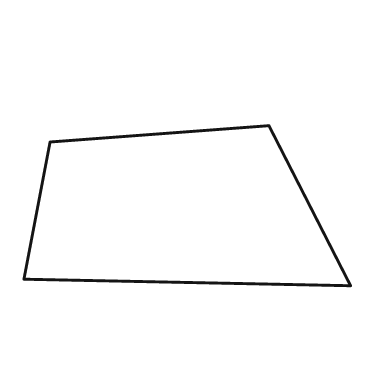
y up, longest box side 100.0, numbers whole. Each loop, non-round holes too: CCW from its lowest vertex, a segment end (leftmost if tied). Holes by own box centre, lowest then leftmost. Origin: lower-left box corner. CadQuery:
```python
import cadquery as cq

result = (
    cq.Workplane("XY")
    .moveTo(100.0, 0.0)
    .lineTo(75.0, 49.0)
    .lineTo(8.0, 44.0)
    .lineTo(0.0, 2.0)
    .close()
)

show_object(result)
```